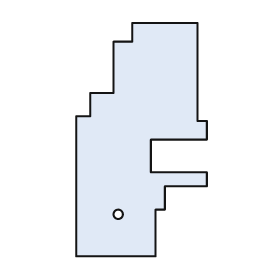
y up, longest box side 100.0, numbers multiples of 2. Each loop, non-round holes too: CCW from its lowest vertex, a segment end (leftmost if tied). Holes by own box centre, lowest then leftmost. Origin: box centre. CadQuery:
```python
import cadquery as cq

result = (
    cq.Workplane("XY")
    .moveTo(-28.0, -50.0)
    .lineTo(6.0, -50.0)
    .lineTo(6.0, -30.0)
    .lineTo(10.0, -30.0)
    .lineTo(10.0, -20.0)
    .lineTo(28.0, -20.0)
    .lineTo(28.0, -14.0)
    .lineTo(4.0, -14.0)
    .lineTo(4.0, 0.0)
    .lineTo(28.0, 0.0)
    .lineTo(28.0, 8.0)
    .lineTo(24.0, 8.0)
    .lineTo(24.0, 50.0)
    .lineTo(-4.0, 50.0)
    .lineTo(-4.0, 42.0)
    .lineTo(-12.0, 42.0)
    .lineTo(-12.0, 20.0)
    .lineTo(-22.0, 20.0)
    .lineTo(-22.0, 10.0)
    .lineTo(-28.0, 10.0)
    .close()
    .moveTo(-10.0, -32.0)
    .circle(2.0)
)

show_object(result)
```